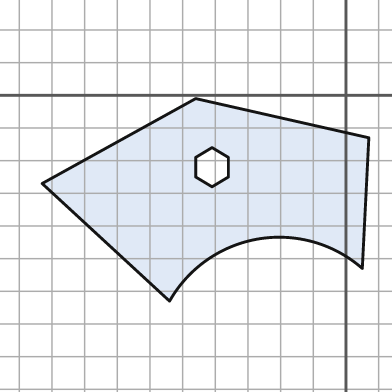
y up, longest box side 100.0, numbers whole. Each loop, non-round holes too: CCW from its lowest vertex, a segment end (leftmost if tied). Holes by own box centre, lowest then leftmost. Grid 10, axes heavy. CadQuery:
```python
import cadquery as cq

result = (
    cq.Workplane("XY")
    .moveTo(-54.0, -63.0)
    .threePointArc((-27.0, -44.0), (5.0, -53.0))
    .lineTo(7.0, -13.0)
    .lineTo(-46.0, -1.0)
    .lineTo(-93.0, -27.0)
    .close()
    .moveTo(-41.0, -28.0)
    .lineTo(-36.0, -25.0)
    .lineTo(-36.0, -19.0)
    .lineTo(-41.0, -16.0)
    .lineTo(-46.0, -19.0)
    .lineTo(-46.0, -25.0)
    .close()
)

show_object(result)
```